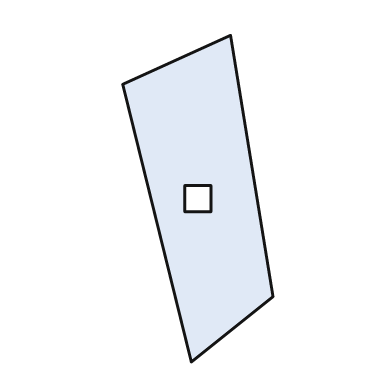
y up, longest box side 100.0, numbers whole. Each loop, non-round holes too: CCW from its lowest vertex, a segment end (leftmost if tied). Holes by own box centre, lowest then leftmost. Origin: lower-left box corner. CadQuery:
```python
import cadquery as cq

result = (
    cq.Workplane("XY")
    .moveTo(21.0, 0.0)
    .lineTo(46.0, 20.0)
    .lineTo(33.0, 100.0)
    .lineTo(0.0, 85.0)
    .close()
    .moveTo(19.0, 46.0)
    .lineTo(27.0, 46.0)
    .lineTo(27.0, 54.0)
    .lineTo(19.0, 54.0)
    .close()
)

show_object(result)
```